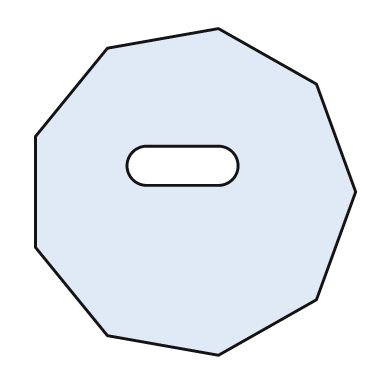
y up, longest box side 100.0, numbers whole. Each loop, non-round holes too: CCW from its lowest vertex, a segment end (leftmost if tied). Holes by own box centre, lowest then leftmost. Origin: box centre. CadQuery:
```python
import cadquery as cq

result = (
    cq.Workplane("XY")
    .moveTo(7.0, -50.0)
    .lineTo(37.0, -33.0)
    .lineTo(49.0, 0.0)
    .lineTo(37.0, 33.0)
    .lineTo(7.0, 50.0)
    .lineTo(-27.0, 44.0)
    .lineTo(-49.0, 17.0)
    .lineTo(-49.0, -17.0)
    .lineTo(-27.0, -44.0)
    .close()
    .moveTo(-15.0, 2.0)
    .lineTo(7.0, 2.0)
    .threePointArc((13.0, 8.0), (7.0, 14.0))
    .lineTo(-15.0, 14.0)
    .threePointArc((-21.0, 8.0), (-15.0, 2.0))
    .close()
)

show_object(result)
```